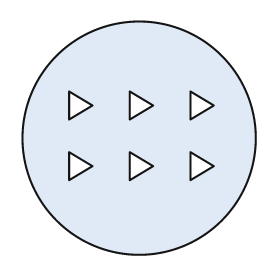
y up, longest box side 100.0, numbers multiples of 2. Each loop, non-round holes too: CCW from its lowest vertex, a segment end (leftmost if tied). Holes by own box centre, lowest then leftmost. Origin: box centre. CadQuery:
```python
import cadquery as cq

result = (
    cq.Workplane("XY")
    .moveTo(0.0, 0.0)
    .circle(50.0)
    .moveTo(-30.0, -18.0)
    .lineTo(-20.0, -12.0)
    .lineTo(-30.0, -6.0)
    .close()
    .moveTo(-4.0, -18.0)
    .lineTo(6.0, -12.0)
    .lineTo(-4.0, -6.0)
    .close()
    .moveTo(22.0, -18.0)
    .lineTo(32.0, -12.0)
    .lineTo(22.0, -6.0)
    .close()
    .moveTo(-30.0, 8.0)
    .lineTo(-20.0, 14.0)
    .lineTo(-30.0, 20.0)
    .close()
    .moveTo(-4.0, 8.0)
    .lineTo(6.0, 14.0)
    .lineTo(-4.0, 20.0)
    .close()
    .moveTo(22.0, 8.0)
    .lineTo(32.0, 14.0)
    .lineTo(22.0, 20.0)
    .close()
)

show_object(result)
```